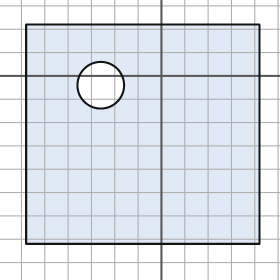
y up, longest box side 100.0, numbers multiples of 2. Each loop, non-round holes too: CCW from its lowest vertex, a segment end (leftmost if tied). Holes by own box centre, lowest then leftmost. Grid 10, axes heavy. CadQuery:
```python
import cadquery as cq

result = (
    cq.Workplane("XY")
    .moveTo(-58.0, -72.0)
    .lineTo(42.0, -72.0)
    .lineTo(42.0, 22.0)
    .lineTo(-58.0, 22.0)
    .close()
    .moveTo(-26.0, -4.0)
    .circle(10.0)
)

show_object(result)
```